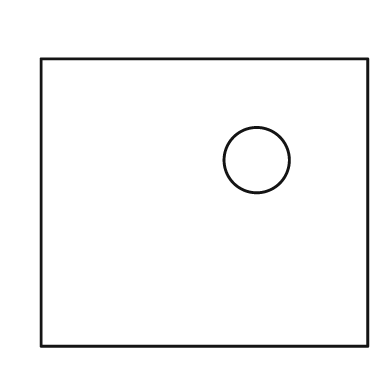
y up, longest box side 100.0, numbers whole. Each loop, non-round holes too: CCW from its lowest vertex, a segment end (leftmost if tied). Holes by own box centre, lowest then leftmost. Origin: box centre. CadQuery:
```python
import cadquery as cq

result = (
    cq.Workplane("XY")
    .moveTo(-50.0, -44.0)
    .lineTo(50.0, -44.0)
    .lineTo(50.0, 44.0)
    .lineTo(-50.0, 44.0)
    .close()
    .moveTo(16.0, 13.0)
    .circle(10.0)
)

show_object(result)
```